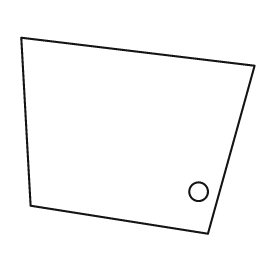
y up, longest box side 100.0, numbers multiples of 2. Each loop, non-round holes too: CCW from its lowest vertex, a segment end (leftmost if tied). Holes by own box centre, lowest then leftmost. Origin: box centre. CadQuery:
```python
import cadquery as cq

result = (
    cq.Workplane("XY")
    .moveTo(30.0, -42.0)
    .lineTo(50.0, 30.0)
    .lineTo(-50.0, 42.0)
    .lineTo(-46.0, -30.0)
    .close()
    .moveTo(26.0, -24.0)
    .circle(4.0)
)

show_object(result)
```